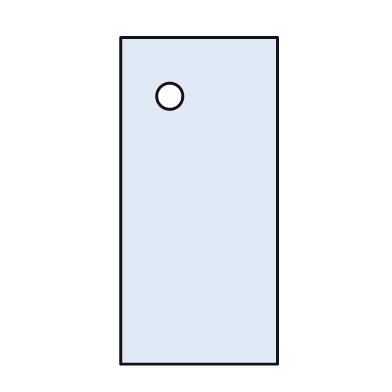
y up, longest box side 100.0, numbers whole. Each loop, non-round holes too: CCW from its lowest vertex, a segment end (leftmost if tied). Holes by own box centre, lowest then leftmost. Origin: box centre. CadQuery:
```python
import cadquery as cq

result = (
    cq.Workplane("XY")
    .moveTo(-24.0, -50.0)
    .lineTo(24.0, -50.0)
    .lineTo(24.0, 50.0)
    .lineTo(-24.0, 50.0)
    .close()
    .moveTo(-9.0, 32.0)
    .circle(4.0)
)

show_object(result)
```